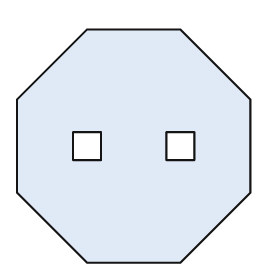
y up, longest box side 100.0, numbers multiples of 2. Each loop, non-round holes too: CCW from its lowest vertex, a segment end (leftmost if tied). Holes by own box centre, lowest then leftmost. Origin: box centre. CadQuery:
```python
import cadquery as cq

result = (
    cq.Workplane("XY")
    .moveTo(-20.0, -50.0)
    .lineTo(20.0, -50.0)
    .lineTo(50.0, -20.0)
    .lineTo(50.0, 20.0)
    .lineTo(20.0, 50.0)
    .lineTo(-20.0, 50.0)
    .lineTo(-50.0, 20.0)
    .lineTo(-50.0, -20.0)
    .close()
    .moveTo(-26.0, -6.0)
    .lineTo(-14.0, -6.0)
    .lineTo(-14.0, 6.0)
    .lineTo(-26.0, 6.0)
    .close()
    .moveTo(14.0, -6.0)
    .lineTo(26.0, -6.0)
    .lineTo(26.0, 6.0)
    .lineTo(14.0, 6.0)
    .close()
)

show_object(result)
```